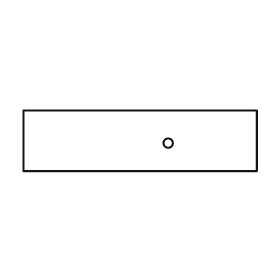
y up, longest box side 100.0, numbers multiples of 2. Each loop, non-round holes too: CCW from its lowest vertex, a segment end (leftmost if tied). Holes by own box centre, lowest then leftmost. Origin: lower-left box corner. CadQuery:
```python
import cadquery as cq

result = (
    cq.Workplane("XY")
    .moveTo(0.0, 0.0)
    .lineTo(100.0, 0.0)
    .lineTo(100.0, 26.0)
    .lineTo(0.0, 26.0)
    .close()
    .moveTo(62.0, 12.0)
    .circle(2.0)
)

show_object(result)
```